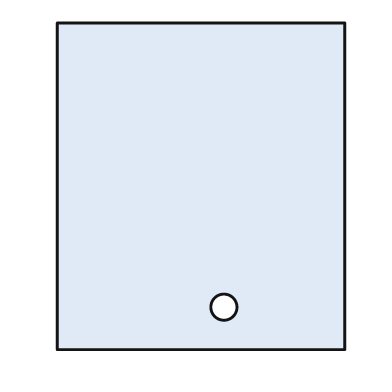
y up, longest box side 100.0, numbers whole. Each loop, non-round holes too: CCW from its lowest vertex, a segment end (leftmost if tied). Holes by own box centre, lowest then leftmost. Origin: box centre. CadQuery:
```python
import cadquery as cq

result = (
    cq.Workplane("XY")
    .moveTo(-44.0, -50.0)
    .lineTo(44.0, -50.0)
    .lineTo(44.0, 50.0)
    .lineTo(-44.0, 50.0)
    .close()
    .moveTo(7.0, -37.0)
    .circle(4.0)
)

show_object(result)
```